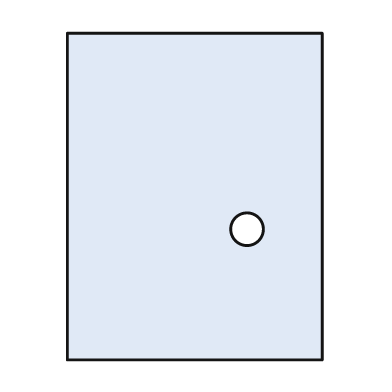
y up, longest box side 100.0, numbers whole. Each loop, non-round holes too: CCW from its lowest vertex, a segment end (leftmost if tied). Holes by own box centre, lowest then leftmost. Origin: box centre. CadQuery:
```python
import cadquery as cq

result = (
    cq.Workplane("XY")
    .moveTo(-39.0, -50.0)
    .lineTo(39.0, -50.0)
    .lineTo(39.0, 50.0)
    .lineTo(-39.0, 50.0)
    .close()
    .moveTo(16.0, -10.0)
    .circle(5.0)
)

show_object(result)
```